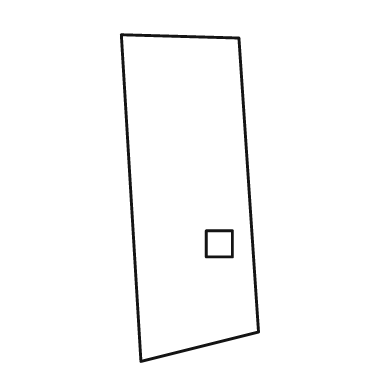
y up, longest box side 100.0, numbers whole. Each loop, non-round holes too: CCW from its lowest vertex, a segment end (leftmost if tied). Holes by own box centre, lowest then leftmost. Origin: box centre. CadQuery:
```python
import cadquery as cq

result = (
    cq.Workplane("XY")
    .moveTo(-15.0, -50.0)
    .lineTo(21.0, -41.0)
    .lineTo(15.0, 49.0)
    .lineTo(-21.0, 50.0)
    .close()
    .moveTo(5.0, -18.0)
    .lineTo(13.0, -18.0)
    .lineTo(13.0, -10.0)
    .lineTo(5.0, -10.0)
    .close()
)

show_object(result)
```